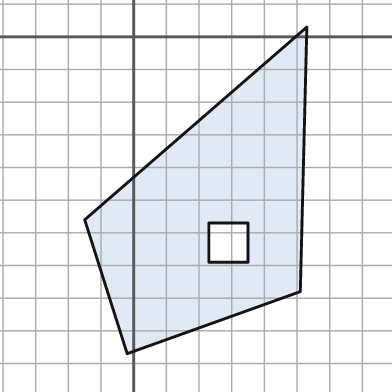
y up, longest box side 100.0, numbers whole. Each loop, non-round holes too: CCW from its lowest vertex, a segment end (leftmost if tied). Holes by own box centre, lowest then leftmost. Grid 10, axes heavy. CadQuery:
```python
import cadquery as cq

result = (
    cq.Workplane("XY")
    .moveTo(-2.0, -97.0)
    .lineTo(51.0, -78.0)
    .lineTo(53.0, 3.0)
    .lineTo(-15.0, -56.0)
    .close()
    .moveTo(23.0, -69.0)
    .lineTo(35.0, -69.0)
    .lineTo(35.0, -57.0)
    .lineTo(23.0, -57.0)
    .close()
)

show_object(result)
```